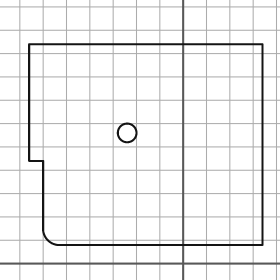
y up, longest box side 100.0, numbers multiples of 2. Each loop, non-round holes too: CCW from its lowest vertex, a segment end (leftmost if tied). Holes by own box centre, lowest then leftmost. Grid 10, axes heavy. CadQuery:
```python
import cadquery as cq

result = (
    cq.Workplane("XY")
    .moveTo(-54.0, 8.0)
    .lineTo(34.0, 8.0)
    .lineTo(34.0, 94.0)
    .lineTo(-66.0, 94.0)
    .lineTo(-66.0, 44.0)
    .lineTo(-60.0, 44.0)
    .lineTo(-60.0, 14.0)
    .threePointArc((-58.0, 10.0), (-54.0, 8.0))
    .close()
    .moveTo(-24.0, 56.0)
    .circle(4.0)
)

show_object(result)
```